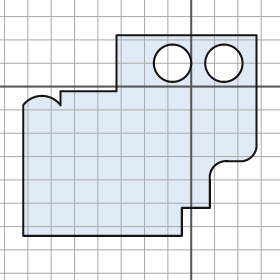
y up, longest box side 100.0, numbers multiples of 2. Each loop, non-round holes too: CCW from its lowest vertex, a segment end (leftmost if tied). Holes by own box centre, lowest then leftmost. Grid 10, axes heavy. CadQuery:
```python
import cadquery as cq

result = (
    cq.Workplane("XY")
    .moveTo(-72.0, -64.0)
    .lineTo(-4.0, -64.0)
    .lineTo(-4.0, -52.0)
    .lineTo(8.0, -52.0)
    .lineTo(8.0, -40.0)
    .threePointArc((10.0, -34.0), (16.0, -32.0))
    .lineTo(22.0, -32.0)
    .threePointArc((26.0, -30.0), (28.0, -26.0))
    .lineTo(28.0, 22.0)
    .lineTo(-32.0, 22.0)
    .lineTo(-32.0, -2.0)
    .lineTo(-56.0, -2.0)
    .lineTo(-56.0, -8.0)
    .threePointArc((-64.0, -4.0), (-72.0, -8.0))
    .close()
    .moveTo(-8.0, 10.0)
    .circle(8.0)
    .moveTo(14.0, 10.0)
    .circle(8.0)
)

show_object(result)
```